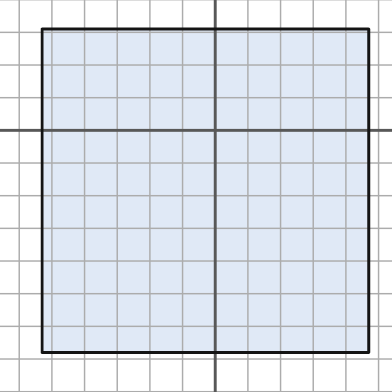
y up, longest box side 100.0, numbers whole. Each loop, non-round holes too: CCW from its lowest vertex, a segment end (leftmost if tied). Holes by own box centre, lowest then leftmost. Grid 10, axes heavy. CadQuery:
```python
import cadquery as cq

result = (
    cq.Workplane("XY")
    .moveTo(-53.0, -68.0)
    .lineTo(47.0, -68.0)
    .lineTo(47.0, 31.0)
    .lineTo(-53.0, 31.0)
    .close()
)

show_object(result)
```